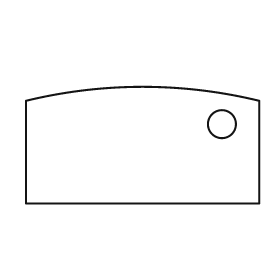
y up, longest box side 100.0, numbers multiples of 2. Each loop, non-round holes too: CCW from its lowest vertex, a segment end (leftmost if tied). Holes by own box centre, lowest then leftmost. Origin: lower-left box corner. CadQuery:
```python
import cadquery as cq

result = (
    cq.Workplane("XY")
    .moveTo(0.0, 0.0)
    .lineTo(100.0, 0.0)
    .lineTo(100.0, 44.0)
    .threePointArc((50.0, 50.0), (0.0, 44.0))
    .close()
    .moveTo(84.0, 34.0)
    .circle(6.0)
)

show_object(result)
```